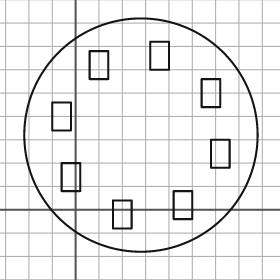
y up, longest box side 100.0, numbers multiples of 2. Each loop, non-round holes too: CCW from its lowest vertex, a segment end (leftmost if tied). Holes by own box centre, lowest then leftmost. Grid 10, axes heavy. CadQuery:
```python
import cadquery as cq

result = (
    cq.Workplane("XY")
    .moveTo(28.0, 32.0)
    .circle(50.0)
    .moveTo(16.0, -8.0)
    .lineTo(24.0, -8.0)
    .lineTo(24.0, 4.0)
    .lineTo(16.0, 4.0)
    .close()
    .moveTo(42.0, -4.0)
    .lineTo(50.0, -4.0)
    .lineTo(50.0, 8.0)
    .lineTo(42.0, 8.0)
    .close()
    .moveTo(-6.0, 8.0)
    .lineTo(2.0, 8.0)
    .lineTo(2.0, 20.0)
    .lineTo(-6.0, 20.0)
    .close()
    .moveTo(58.0, 18.0)
    .lineTo(66.0, 18.0)
    .lineTo(66.0, 30.0)
    .lineTo(58.0, 30.0)
    .close()
    .moveTo(-10.0, 34.0)
    .lineTo(-2.0, 34.0)
    .lineTo(-2.0, 46.0)
    .lineTo(-10.0, 46.0)
    .close()
    .moveTo(54.0, 44.0)
    .lineTo(62.0, 44.0)
    .lineTo(62.0, 56.0)
    .lineTo(54.0, 56.0)
    .close()
    .moveTo(6.0, 56.0)
    .lineTo(14.0, 56.0)
    .lineTo(14.0, 68.0)
    .lineTo(6.0, 68.0)
    .close()
    .moveTo(32.0, 60.0)
    .lineTo(40.0, 60.0)
    .lineTo(40.0, 72.0)
    .lineTo(32.0, 72.0)
    .close()
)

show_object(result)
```